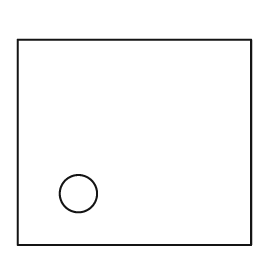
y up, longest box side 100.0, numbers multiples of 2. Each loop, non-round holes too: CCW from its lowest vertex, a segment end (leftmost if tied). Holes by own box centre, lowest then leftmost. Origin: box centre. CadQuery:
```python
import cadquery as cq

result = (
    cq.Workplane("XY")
    .moveTo(-50.0, -44.0)
    .lineTo(50.0, -44.0)
    .lineTo(50.0, 44.0)
    .lineTo(-50.0, 44.0)
    .close()
    .moveTo(-24.0, -22.0)
    .circle(8.0)
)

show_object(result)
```